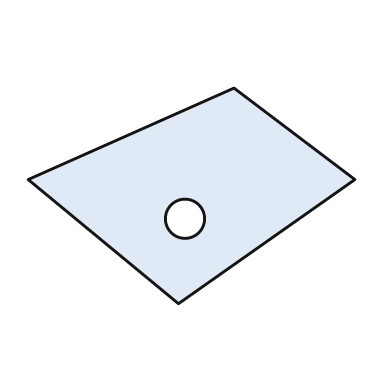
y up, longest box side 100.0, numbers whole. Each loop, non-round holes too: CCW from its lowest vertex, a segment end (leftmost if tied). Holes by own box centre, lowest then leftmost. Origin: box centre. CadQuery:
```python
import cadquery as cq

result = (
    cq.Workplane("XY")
    .moveTo(-4.0, -33.0)
    .lineTo(50.0, 5.0)
    .lineTo(13.0, 33.0)
    .lineTo(-50.0, 5.0)
    .close()
    .moveTo(-2.0, -7.0)
    .circle(6.0)
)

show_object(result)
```